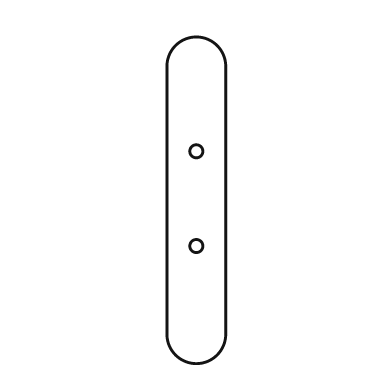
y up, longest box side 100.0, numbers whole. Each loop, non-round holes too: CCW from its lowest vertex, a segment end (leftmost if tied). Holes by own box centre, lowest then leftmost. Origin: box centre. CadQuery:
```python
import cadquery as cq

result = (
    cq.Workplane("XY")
    .moveTo(-9.0, -41.0)
    .threePointArc((0.0, -50.0), (9.0, -41.0))
    .lineTo(9.0, 41.0)
    .threePointArc((0.0, 50.0), (-9.0, 41.0))
    .close()
    .moveTo(0.0, -14.0)
    .circle(2.0)
    .moveTo(0.0, 15.0)
    .circle(2.0)
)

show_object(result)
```